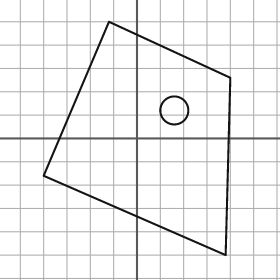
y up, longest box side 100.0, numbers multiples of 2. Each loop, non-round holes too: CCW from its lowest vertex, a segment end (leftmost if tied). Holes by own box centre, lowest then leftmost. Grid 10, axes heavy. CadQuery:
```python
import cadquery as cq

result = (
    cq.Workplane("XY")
    .moveTo(38.0, -50.0)
    .lineTo(40.0, 26.0)
    .lineTo(-12.0, 50.0)
    .lineTo(-40.0, -16.0)
    .close()
    .moveTo(16.0, 12.0)
    .circle(6.0)
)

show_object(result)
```